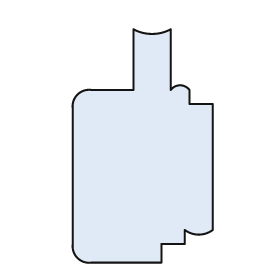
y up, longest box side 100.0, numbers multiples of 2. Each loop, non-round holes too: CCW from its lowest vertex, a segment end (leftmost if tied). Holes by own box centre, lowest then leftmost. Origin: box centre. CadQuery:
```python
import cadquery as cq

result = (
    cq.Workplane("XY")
    .moveTo(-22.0, -50.0)
    .lineTo(8.0, -50.0)
    .lineTo(8.0, -42.0)
    .lineTo(18.0, -42.0)
    .lineTo(18.0, -36.0)
    .threePointArc((24.0, -38.0), (30.0, -36.0))
    .lineTo(30.0, 18.0)
    .lineTo(20.0, 18.0)
    .lineTo(20.0, 24.0)
    .threePointArc((16.0, 26.0), (12.0, 24.0))
    .lineTo(12.0, 50.0)
    .threePointArc((4.0, 48.0), (-4.0, 50.0))
    .lineTo(-4.0, 24.0)
    .lineTo(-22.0, 24.0)
    .threePointArc((-28.0, 22.0), (-30.0, 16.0))
    .lineTo(-30.0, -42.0)
    .threePointArc((-28.0, -48.0), (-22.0, -50.0))
    .close()
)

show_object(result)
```